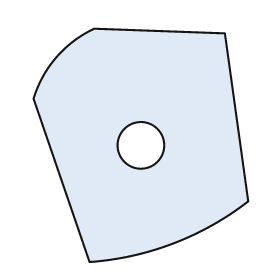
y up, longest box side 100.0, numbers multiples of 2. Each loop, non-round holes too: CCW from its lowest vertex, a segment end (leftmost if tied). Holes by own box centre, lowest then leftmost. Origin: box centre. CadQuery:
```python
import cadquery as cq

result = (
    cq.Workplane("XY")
    .moveTo(-22.0, -50.0)
    .threePointArc((14.0, -42.0), (46.0, -24.0))
    .lineTo(36.0, 48.0)
    .lineTo(-20.0, 50.0)
    .threePointArc((-36.0, 38.0), (-46.0, 20.0))
    .close()
    .moveTo(0.0, 0.0)
    .circle(10.0)
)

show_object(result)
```